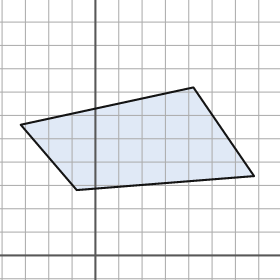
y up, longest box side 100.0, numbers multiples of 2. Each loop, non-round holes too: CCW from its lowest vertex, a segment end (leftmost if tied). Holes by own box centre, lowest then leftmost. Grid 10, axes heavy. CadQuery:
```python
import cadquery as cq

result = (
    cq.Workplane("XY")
    .moveTo(-8.0, 28.0)
    .lineTo(68.0, 34.0)
    .lineTo(42.0, 72.0)
    .lineTo(-32.0, 56.0)
    .close()
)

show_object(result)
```